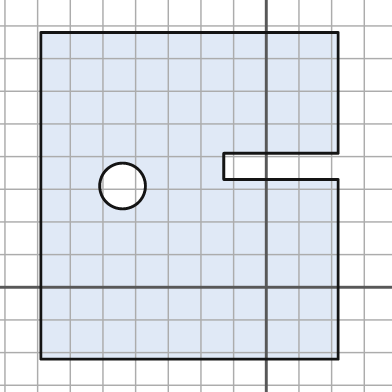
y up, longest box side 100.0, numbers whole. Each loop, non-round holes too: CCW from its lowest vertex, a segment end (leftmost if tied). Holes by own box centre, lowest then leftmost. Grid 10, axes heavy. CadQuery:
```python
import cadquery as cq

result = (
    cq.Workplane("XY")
    .moveTo(-69.0, -22.0)
    .lineTo(22.0, -22.0)
    .lineTo(22.0, 33.0)
    .lineTo(-13.0, 33.0)
    .lineTo(-13.0, 41.0)
    .lineTo(22.0, 41.0)
    .lineTo(22.0, 78.0)
    .lineTo(-69.0, 78.0)
    .close()
    .moveTo(-44.0, 31.0)
    .circle(7.0)
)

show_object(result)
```